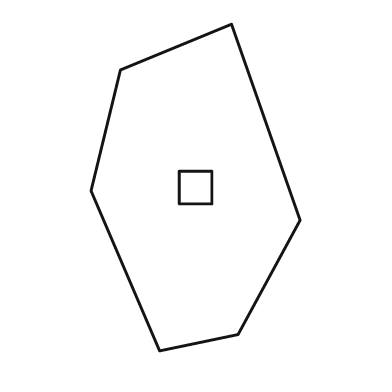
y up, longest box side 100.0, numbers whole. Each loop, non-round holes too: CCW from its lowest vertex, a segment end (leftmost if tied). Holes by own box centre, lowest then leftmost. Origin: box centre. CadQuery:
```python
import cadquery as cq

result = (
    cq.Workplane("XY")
    .moveTo(-11.0, -50.0)
    .lineTo(13.0, -45.0)
    .lineTo(32.0, -10.0)
    .lineTo(11.0, 50.0)
    .lineTo(-23.0, 36.0)
    .lineTo(-32.0, -1.0)
    .close()
    .moveTo(-5.0, -5.0)
    .lineTo(5.0, -5.0)
    .lineTo(5.0, 5.0)
    .lineTo(-5.0, 5.0)
    .close()
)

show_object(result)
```